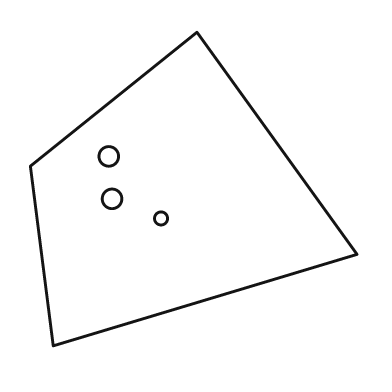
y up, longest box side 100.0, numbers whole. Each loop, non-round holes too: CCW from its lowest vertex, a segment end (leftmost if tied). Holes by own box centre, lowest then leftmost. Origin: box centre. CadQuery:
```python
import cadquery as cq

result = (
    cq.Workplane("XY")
    .moveTo(-43.0, -48.0)
    .lineTo(50.0, -20.0)
    .lineTo(1.0, 48.0)
    .lineTo(-50.0, 7.0)
    .close()
    .moveTo(-10.0, -9.0)
    .circle(2.0)
    .moveTo(-25.0, -3.0)
    .circle(3.0)
    .moveTo(-26.0, 10.0)
    .circle(3.0)
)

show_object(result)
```